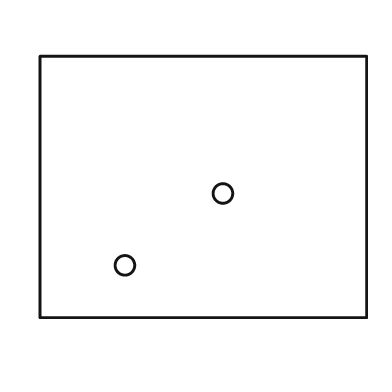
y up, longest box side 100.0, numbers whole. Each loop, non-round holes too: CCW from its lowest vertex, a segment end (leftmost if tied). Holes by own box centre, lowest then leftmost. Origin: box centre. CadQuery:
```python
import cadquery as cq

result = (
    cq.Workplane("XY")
    .moveTo(-50.0, -40.0)
    .lineTo(50.0, -40.0)
    .lineTo(50.0, 40.0)
    .lineTo(-50.0, 40.0)
    .close()
    .moveTo(-24.0, -24.0)
    .circle(3.0)
    .moveTo(6.0, -2.0)
    .circle(3.0)
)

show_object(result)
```